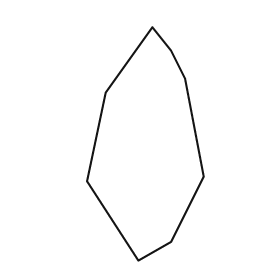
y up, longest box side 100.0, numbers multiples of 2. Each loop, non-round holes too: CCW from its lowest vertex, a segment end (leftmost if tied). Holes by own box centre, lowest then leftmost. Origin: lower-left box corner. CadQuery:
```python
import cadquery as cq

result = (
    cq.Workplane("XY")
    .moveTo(22.0, 0.0)
    .lineTo(36.0, 8.0)
    .lineTo(50.0, 36.0)
    .lineTo(42.0, 78.0)
    .lineTo(36.0, 90.0)
    .lineTo(28.0, 100.0)
    .lineTo(8.0, 72.0)
    .lineTo(0.0, 34.0)
    .close()
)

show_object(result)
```